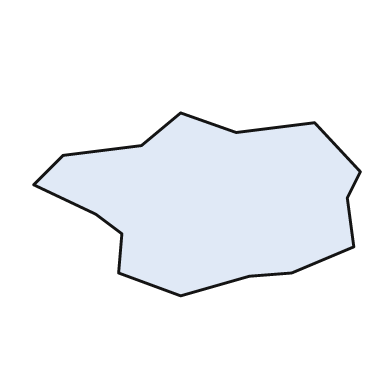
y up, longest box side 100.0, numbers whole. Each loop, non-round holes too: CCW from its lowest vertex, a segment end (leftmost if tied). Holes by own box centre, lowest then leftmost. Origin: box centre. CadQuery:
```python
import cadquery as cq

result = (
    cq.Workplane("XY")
    .moveTo(-5.0, -28.0)
    .lineTo(16.0, -22.0)
    .lineTo(29.0, -21.0)
    .lineTo(48.0, -13.0)
    .lineTo(46.0, 2.0)
    .lineTo(50.0, 10.0)
    .lineTo(36.0, 25.0)
    .lineTo(12.0, 22.0)
    .lineTo(-5.0, 28.0)
    .lineTo(-17.0, 18.0)
    .lineTo(-41.0, 15.0)
    .lineTo(-50.0, 6.0)
    .lineTo(-31.0, -3.0)
    .lineTo(-23.0, -9.0)
    .lineTo(-24.0, -21.0)
    .close()
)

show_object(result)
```